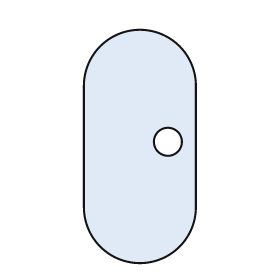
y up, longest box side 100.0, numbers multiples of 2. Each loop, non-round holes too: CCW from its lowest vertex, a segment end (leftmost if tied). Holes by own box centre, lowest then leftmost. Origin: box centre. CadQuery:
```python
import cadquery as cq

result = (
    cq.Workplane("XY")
    .moveTo(-24.0, -26.0)
    .threePointArc((0.0, -50.0), (24.0, -26.0))
    .lineTo(24.0, 26.0)
    .threePointArc((0.0, 50.0), (-24.0, 26.0))
    .close()
    .moveTo(12.0, 2.0)
    .circle(6.0)
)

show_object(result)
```